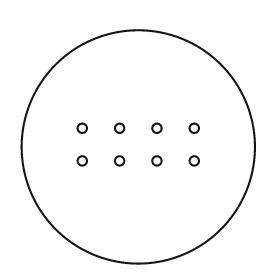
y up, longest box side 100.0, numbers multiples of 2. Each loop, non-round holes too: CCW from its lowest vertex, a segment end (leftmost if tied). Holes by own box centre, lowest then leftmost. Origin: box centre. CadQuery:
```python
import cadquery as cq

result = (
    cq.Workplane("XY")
    .moveTo(0.0, 0.0)
    .circle(50.0)
    .moveTo(-24.0, -6.0)
    .circle(2.0)
    .moveTo(-8.0, -6.0)
    .circle(2.0)
    .moveTo(8.0, -6.0)
    .circle(2.0)
    .moveTo(24.0, -6.0)
    .circle(2.0)
    .moveTo(-24.0, 8.0)
    .circle(2.0)
    .moveTo(-8.0, 8.0)
    .circle(2.0)
    .moveTo(8.0, 8.0)
    .circle(2.0)
    .moveTo(24.0, 8.0)
    .circle(2.0)
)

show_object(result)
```